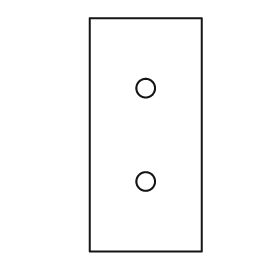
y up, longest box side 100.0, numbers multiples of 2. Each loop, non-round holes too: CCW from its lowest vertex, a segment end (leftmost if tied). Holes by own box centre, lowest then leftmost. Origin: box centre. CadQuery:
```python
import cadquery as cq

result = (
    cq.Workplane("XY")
    .moveTo(-24.0, -50.0)
    .lineTo(24.0, -50.0)
    .lineTo(24.0, 50.0)
    .lineTo(-24.0, 50.0)
    .close()
    .moveTo(0.0, -20.0)
    .circle(4.0)
    .moveTo(0.0, 20.0)
    .circle(4.0)
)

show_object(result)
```